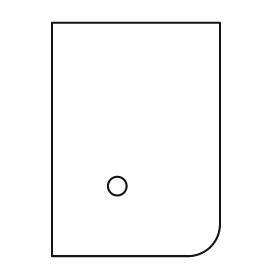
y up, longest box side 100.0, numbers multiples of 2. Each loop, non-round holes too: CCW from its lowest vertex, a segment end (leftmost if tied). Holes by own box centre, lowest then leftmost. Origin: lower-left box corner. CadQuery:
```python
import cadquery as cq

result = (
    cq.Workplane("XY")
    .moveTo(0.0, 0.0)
    .lineTo(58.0, 0.0)
    .threePointArc((68.0, 4.0), (72.0, 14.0))
    .lineTo(72.0, 100.0)
    .lineTo(0.0, 100.0)
    .close()
    .moveTo(28.0, 30.0)
    .circle(4.0)
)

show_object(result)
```